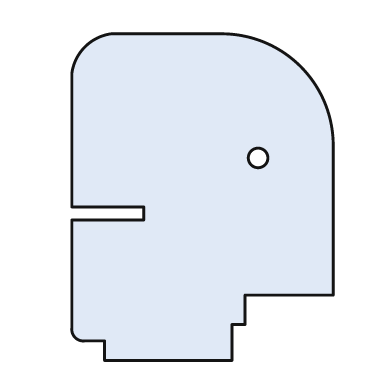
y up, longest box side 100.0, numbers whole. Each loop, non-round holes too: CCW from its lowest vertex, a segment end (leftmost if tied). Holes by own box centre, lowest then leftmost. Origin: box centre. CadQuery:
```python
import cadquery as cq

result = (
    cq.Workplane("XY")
    .moveTo(-30.0, -50.0)
    .lineTo(9.0, -50.0)
    .lineTo(9.0, -39.0)
    .lineTo(13.0, -39.0)
    .lineTo(13.0, -30.0)
    .lineTo(40.0, -30.0)
    .lineTo(40.0, 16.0)
    .threePointArc((30.0, 40.0), (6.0, 50.0))
    .lineTo(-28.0, 50.0)
    .threePointArc((-36.0, 46.0), (-40.0, 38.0))
    .lineTo(-40.0, -3.0)
    .lineTo(-18.0, -3.0)
    .lineTo(-18.0, -7.0)
    .lineTo(-40.0, -7.0)
    .lineTo(-40.0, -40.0)
    .threePointArc((-39.0, -43.0), (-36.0, -44.0))
    .lineTo(-30.0, -44.0)
    .close()
    .moveTo(17.0, 12.0)
    .circle(3.0)
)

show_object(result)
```